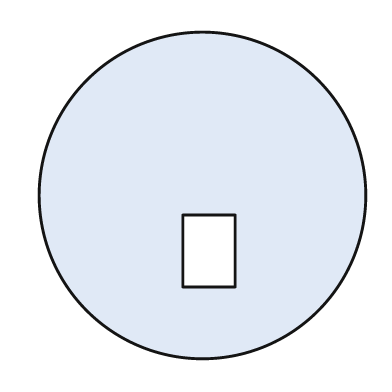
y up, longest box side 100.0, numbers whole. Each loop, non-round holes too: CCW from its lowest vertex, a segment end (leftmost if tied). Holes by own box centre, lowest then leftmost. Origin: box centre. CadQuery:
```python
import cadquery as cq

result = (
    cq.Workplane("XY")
    .moveTo(0.0, 0.0)
    .circle(50.0)
    .moveTo(-6.0, -28.0)
    .lineTo(10.0, -28.0)
    .lineTo(10.0, -6.0)
    .lineTo(-6.0, -6.0)
    .close()
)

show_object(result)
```